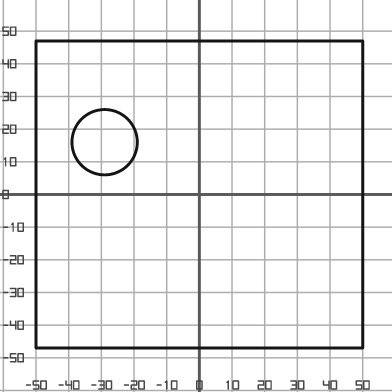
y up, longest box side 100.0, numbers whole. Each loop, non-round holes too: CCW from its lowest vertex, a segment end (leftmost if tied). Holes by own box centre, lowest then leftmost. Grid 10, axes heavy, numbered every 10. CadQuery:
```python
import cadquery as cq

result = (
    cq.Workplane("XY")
    .moveTo(-50.0, -47.0)
    .lineTo(50.0, -47.0)
    .lineTo(50.0, 47.0)
    .lineTo(-50.0, 47.0)
    .close()
    .moveTo(-29.0, 16.0)
    .circle(10.0)
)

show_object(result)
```